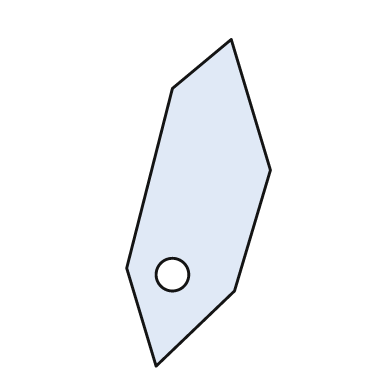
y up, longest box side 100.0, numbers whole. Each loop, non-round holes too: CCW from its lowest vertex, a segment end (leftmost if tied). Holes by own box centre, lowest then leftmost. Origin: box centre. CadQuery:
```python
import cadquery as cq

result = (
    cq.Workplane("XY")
    .moveTo(-13.0, -50.0)
    .lineTo(11.0, -27.0)
    .lineTo(22.0, 10.0)
    .lineTo(10.0, 50.0)
    .lineTo(-8.0, 35.0)
    .lineTo(-22.0, -20.0)
    .close()
    .moveTo(-8.0, -22.0)
    .circle(5.0)
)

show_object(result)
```